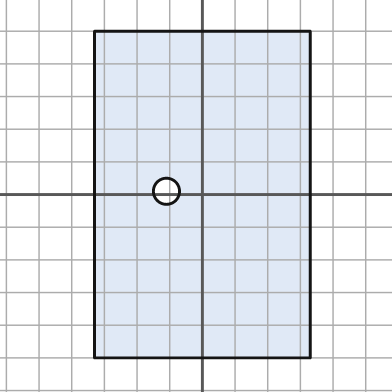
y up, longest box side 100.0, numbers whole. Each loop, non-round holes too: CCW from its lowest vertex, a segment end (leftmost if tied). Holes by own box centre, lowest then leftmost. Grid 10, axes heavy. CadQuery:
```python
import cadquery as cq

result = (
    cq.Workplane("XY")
    .moveTo(-33.0, -50.0)
    .lineTo(33.0, -50.0)
    .lineTo(33.0, 50.0)
    .lineTo(-33.0, 50.0)
    .close()
    .moveTo(-11.0, 1.0)
    .circle(4.0)
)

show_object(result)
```